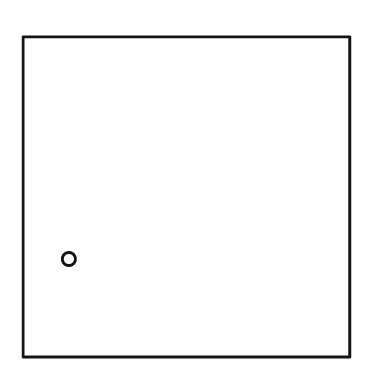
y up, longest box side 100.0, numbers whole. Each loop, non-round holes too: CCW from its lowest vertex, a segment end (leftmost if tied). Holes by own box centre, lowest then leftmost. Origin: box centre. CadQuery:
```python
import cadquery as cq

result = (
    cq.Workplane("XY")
    .moveTo(-50.0, -49.0)
    .lineTo(50.0, -49.0)
    .lineTo(50.0, 49.0)
    .lineTo(-50.0, 49.0)
    .close()
    .moveTo(-36.0, -19.0)
    .circle(2.0)
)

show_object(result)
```